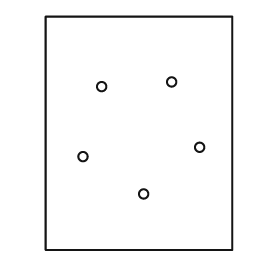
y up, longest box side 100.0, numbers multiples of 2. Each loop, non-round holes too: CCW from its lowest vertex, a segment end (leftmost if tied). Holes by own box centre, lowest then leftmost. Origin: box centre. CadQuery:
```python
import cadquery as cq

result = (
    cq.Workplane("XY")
    .moveTo(-40.0, -50.0)
    .lineTo(40.0, -50.0)
    .lineTo(40.0, 50.0)
    .lineTo(-40.0, 50.0)
    .close()
    .moveTo(2.0, -26.0)
    .circle(2.0)
    .moveTo(-24.0, -10.0)
    .circle(2.0)
    .moveTo(26.0, -6.0)
    .circle(2.0)
    .moveTo(-16.0, 20.0)
    .circle(2.0)
    .moveTo(14.0, 22.0)
    .circle(2.0)
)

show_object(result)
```